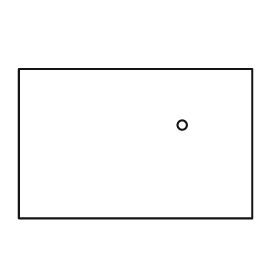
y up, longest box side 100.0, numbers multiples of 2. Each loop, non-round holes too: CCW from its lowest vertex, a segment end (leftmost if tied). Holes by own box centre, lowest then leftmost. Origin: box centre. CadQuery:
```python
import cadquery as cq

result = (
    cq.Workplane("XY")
    .moveTo(-50.0, -32.0)
    .lineTo(50.0, -32.0)
    .lineTo(50.0, 32.0)
    .lineTo(-50.0, 32.0)
    .close()
    .moveTo(20.0, 8.0)
    .circle(2.0)
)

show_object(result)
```